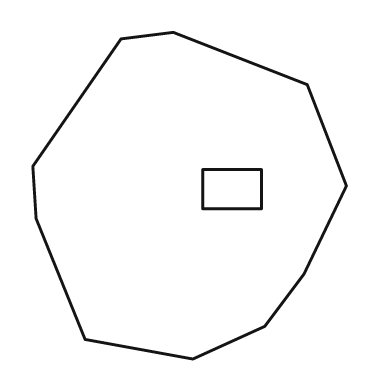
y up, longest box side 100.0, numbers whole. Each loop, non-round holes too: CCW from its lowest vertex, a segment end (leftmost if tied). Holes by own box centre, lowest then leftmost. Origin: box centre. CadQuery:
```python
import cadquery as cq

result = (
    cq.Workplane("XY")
    .moveTo(1.0, -50.0)
    .lineTo(23.0, -40.0)
    .lineTo(35.0, -24.0)
    .lineTo(48.0, 3.0)
    .lineTo(36.0, 34.0)
    .lineTo(-5.0, 50.0)
    .lineTo(-21.0, 48.0)
    .lineTo(-48.0, 9.0)
    .lineTo(-47.0, -7.0)
    .lineTo(-32.0, -44.0)
    .close()
    .moveTo(4.0, -4.0)
    .lineTo(22.0, -4.0)
    .lineTo(22.0, 8.0)
    .lineTo(4.0, 8.0)
    .close()
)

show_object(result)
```